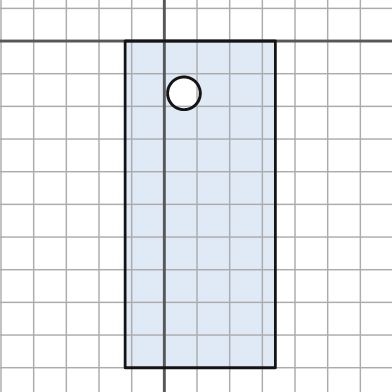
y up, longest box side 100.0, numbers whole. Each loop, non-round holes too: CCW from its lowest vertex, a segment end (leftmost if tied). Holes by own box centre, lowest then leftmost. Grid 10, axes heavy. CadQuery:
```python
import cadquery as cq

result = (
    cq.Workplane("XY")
    .moveTo(-12.0, -100.0)
    .lineTo(34.0, -100.0)
    .lineTo(34.0, 0.0)
    .lineTo(-12.0, 0.0)
    .close()
    .moveTo(6.0, -16.0)
    .circle(5.0)
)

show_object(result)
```